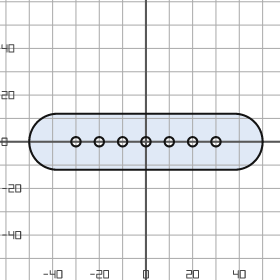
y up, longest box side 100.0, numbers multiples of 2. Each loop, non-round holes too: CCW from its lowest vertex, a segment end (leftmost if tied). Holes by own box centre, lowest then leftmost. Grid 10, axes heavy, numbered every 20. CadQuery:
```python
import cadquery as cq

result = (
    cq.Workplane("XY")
    .moveTo(-38.0, -12.0)
    .lineTo(38.0, -12.0)
    .threePointArc((50.0, 0.0), (38.0, 12.0))
    .lineTo(-38.0, 12.0)
    .threePointArc((-50.0, 0.0), (-38.0, -12.0))
    .close()
    .moveTo(-30.0, 0.0)
    .circle(2.0)
    .moveTo(-20.0, 0.0)
    .circle(2.0)
    .moveTo(-10.0, 0.0)
    .circle(2.0)
    .moveTo(0.0, 0.0)
    .circle(2.0)
    .moveTo(10.0, 0.0)
    .circle(2.0)
    .moveTo(20.0, 0.0)
    .circle(2.0)
    .moveTo(30.0, 0.0)
    .circle(2.0)
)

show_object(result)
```